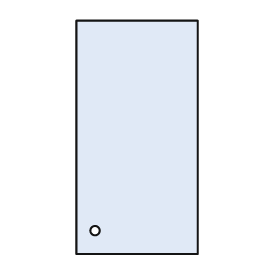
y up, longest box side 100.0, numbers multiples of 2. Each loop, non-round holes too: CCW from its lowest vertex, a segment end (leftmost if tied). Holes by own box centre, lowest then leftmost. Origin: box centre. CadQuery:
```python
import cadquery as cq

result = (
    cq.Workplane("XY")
    .moveTo(-26.0, -50.0)
    .lineTo(26.0, -50.0)
    .lineTo(26.0, 50.0)
    .lineTo(-26.0, 50.0)
    .close()
    .moveTo(-18.0, -40.0)
    .circle(2.0)
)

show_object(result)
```